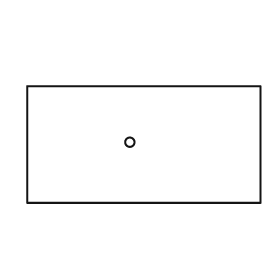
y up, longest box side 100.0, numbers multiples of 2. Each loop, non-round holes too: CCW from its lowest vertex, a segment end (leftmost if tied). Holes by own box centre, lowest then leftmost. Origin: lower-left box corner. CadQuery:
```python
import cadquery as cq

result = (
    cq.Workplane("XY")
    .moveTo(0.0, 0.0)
    .lineTo(100.0, 0.0)
    .lineTo(100.0, 50.0)
    .lineTo(0.0, 50.0)
    .close()
    .moveTo(44.0, 26.0)
    .circle(2.0)
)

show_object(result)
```